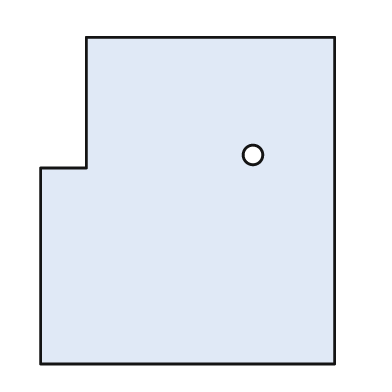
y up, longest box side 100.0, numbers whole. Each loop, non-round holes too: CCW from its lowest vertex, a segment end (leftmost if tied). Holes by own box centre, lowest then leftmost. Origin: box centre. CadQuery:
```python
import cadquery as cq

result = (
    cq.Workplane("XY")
    .moveTo(-45.0, -50.0)
    .lineTo(45.0, -50.0)
    .lineTo(45.0, 50.0)
    .lineTo(-31.0, 50.0)
    .lineTo(-31.0, 10.0)
    .lineTo(-45.0, 10.0)
    .close()
    .moveTo(20.0, 14.0)
    .circle(3.0)
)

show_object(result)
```